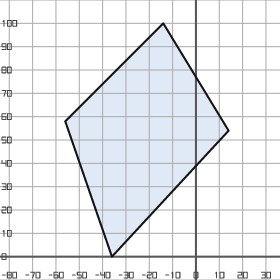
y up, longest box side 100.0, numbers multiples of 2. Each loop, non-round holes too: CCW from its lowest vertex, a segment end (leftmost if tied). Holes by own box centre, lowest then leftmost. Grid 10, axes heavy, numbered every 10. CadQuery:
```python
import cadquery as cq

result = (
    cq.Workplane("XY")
    .moveTo(-36.0, 0.0)
    .lineTo(14.0, 54.0)
    .lineTo(-14.0, 100.0)
    .lineTo(-56.0, 58.0)
    .close()
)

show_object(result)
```